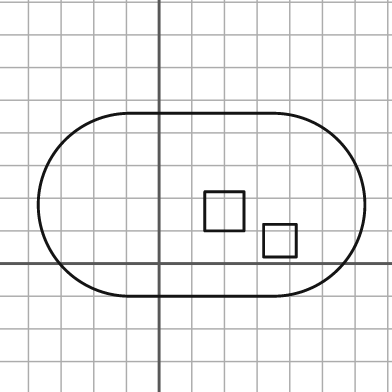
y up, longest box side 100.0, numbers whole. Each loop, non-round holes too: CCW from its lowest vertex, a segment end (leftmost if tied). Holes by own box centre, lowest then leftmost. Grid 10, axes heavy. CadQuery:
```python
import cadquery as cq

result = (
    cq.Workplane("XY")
    .moveTo(-9.0, -10.0)
    .lineTo(35.0, -10.0)
    .threePointArc((63.0, 18.0), (35.0, 46.0))
    .lineTo(-9.0, 46.0)
    .threePointArc((-37.0, 18.0), (-9.0, -10.0))
    .close()
    .moveTo(32.0, 2.0)
    .lineTo(42.0, 2.0)
    .lineTo(42.0, 12.0)
    .lineTo(32.0, 12.0)
    .close()
    .moveTo(14.0, 10.0)
    .lineTo(26.0, 10.0)
    .lineTo(26.0, 22.0)
    .lineTo(14.0, 22.0)
    .close()
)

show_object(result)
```